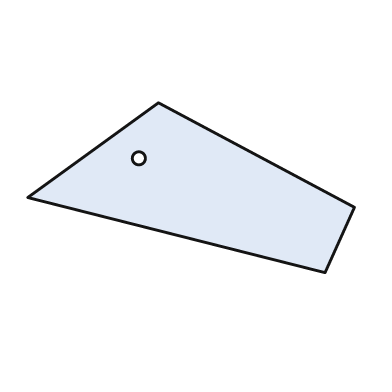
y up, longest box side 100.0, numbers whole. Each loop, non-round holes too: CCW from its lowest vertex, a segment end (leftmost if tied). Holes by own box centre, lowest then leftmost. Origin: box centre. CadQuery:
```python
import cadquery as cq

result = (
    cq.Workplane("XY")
    .moveTo(41.0, -26.0)
    .lineTo(50.0, -6.0)
    .lineTo(-10.0, 26.0)
    .lineTo(-50.0, -3.0)
    .close()
    .moveTo(-16.0, 9.0)
    .circle(2.0)
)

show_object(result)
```